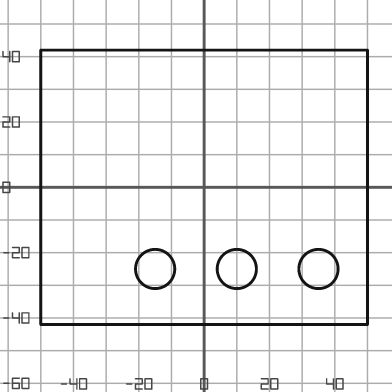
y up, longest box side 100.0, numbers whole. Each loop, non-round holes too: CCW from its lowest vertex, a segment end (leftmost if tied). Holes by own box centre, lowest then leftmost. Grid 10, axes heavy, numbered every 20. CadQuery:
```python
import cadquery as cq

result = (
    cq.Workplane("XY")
    .moveTo(-50.0, -42.0)
    .lineTo(50.0, -42.0)
    .lineTo(50.0, 42.0)
    .lineTo(-50.0, 42.0)
    .close()
    .moveTo(-15.0, -25.0)
    .circle(6.0)
    .moveTo(10.0, -25.0)
    .circle(6.0)
    .moveTo(35.0, -25.0)
    .circle(6.0)
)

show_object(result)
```